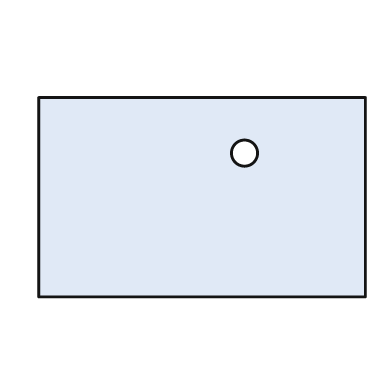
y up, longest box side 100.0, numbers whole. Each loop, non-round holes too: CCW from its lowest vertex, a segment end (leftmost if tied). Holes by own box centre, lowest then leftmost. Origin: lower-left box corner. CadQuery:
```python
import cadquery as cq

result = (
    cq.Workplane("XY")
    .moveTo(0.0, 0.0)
    .lineTo(100.0, 0.0)
    .lineTo(100.0, 61.0)
    .lineTo(0.0, 61.0)
    .close()
    .moveTo(63.0, 44.0)
    .circle(4.0)
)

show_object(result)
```